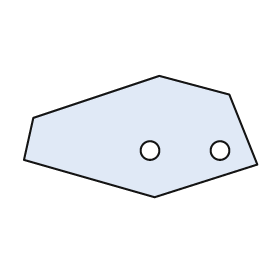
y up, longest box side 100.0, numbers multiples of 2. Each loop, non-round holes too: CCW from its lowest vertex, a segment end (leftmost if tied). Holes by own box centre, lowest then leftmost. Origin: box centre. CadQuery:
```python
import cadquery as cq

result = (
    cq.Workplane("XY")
    .moveTo(6.0, -26.0)
    .lineTo(50.0, -12.0)
    .lineTo(38.0, 18.0)
    .lineTo(8.0, 26.0)
    .lineTo(-46.0, 8.0)
    .lineTo(-50.0, -10.0)
    .close()
    .moveTo(4.0, -6.0)
    .circle(4.0)
    .moveTo(34.0, -6.0)
    .circle(4.0)
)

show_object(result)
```